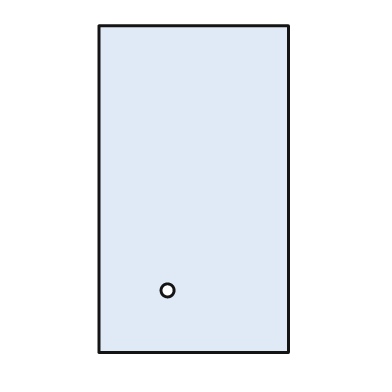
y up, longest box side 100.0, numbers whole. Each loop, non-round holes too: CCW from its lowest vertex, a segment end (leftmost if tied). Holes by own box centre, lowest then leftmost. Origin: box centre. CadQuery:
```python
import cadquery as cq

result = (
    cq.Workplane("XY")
    .moveTo(-29.0, -50.0)
    .lineTo(29.0, -50.0)
    .lineTo(29.0, 50.0)
    .lineTo(-29.0, 50.0)
    .close()
    .moveTo(-8.0, -31.0)
    .circle(2.0)
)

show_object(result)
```